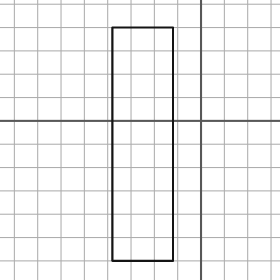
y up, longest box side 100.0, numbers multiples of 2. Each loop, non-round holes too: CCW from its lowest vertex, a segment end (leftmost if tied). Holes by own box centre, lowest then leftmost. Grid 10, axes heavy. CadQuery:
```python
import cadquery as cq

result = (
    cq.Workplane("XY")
    .moveTo(-38.0, -60.0)
    .lineTo(-12.0, -60.0)
    .lineTo(-12.0, 40.0)
    .lineTo(-38.0, 40.0)
    .close()
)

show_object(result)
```